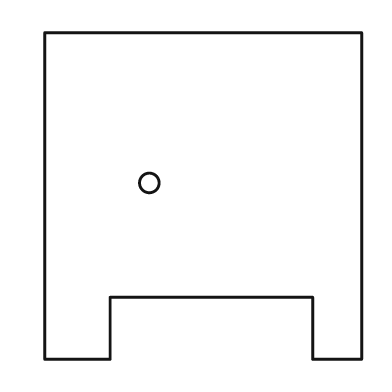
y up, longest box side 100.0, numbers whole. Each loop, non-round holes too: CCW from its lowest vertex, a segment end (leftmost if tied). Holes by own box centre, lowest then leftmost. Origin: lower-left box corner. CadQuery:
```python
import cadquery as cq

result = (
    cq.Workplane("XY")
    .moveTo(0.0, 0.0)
    .lineTo(20.0, 0.0)
    .lineTo(20.0, 19.0)
    .lineTo(82.0, 19.0)
    .lineTo(82.0, 0.0)
    .lineTo(97.0, 0.0)
    .lineTo(97.0, 100.0)
    .lineTo(0.0, 100.0)
    .close()
    .moveTo(32.0, 54.0)
    .circle(3.0)
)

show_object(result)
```